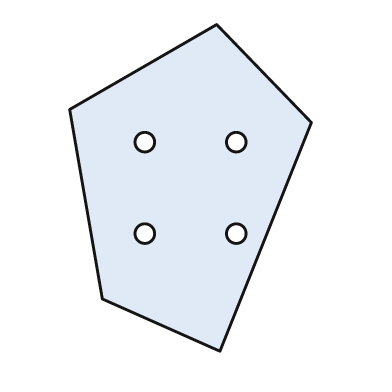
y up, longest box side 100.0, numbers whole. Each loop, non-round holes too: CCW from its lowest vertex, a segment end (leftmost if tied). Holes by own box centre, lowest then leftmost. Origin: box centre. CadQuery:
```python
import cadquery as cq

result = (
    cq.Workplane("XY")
    .moveTo(9.0, -50.0)
    .lineTo(37.0, 20.0)
    .lineTo(8.0, 50.0)
    .lineTo(-37.0, 24.0)
    .lineTo(-27.0, -34.0)
    .close()
    .moveTo(-14.0, -14.0)
    .circle(3.0)
    .moveTo(14.0, -14.0)
    .circle(3.0)
    .moveTo(-14.0, 14.0)
    .circle(3.0)
    .moveTo(14.0, 14.0)
    .circle(3.0)
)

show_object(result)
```